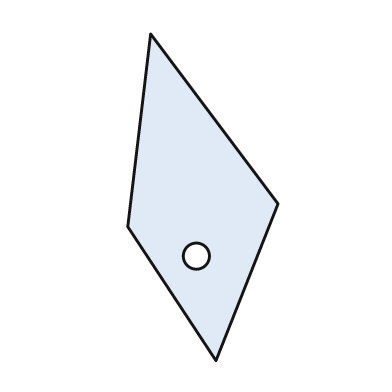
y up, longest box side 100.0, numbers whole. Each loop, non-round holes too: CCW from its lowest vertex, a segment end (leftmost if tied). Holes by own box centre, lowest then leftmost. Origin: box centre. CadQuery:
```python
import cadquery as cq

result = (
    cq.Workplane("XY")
    .moveTo(4.0, -50.0)
    .lineTo(23.0, -2.0)
    .lineTo(-16.0, 50.0)
    .lineTo(-23.0, -9.0)
    .close()
    .moveTo(-2.0, -18.0)
    .circle(4.0)
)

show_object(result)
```